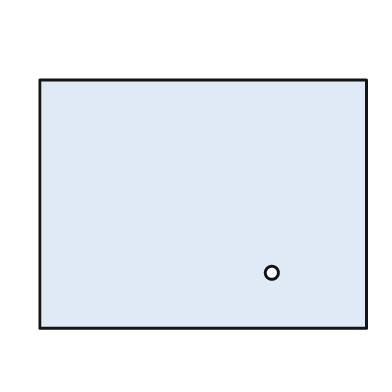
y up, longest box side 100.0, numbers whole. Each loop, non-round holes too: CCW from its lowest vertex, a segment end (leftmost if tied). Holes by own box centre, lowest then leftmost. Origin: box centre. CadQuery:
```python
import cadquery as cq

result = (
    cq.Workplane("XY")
    .moveTo(-50.0, -38.0)
    .lineTo(50.0, -38.0)
    .lineTo(50.0, 38.0)
    .lineTo(-50.0, 38.0)
    .close()
    .moveTo(21.0, -21.0)
    .circle(2.0)
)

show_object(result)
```